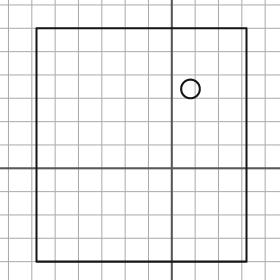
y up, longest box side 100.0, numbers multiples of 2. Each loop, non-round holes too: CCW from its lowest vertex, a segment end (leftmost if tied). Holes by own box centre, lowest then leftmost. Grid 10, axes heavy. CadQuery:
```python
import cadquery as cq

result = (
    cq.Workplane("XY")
    .moveTo(-58.0, -40.0)
    .lineTo(32.0, -40.0)
    .lineTo(32.0, 60.0)
    .lineTo(-58.0, 60.0)
    .close()
    .moveTo(8.0, 34.0)
    .circle(4.0)
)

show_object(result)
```